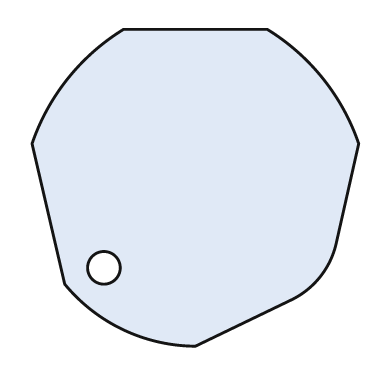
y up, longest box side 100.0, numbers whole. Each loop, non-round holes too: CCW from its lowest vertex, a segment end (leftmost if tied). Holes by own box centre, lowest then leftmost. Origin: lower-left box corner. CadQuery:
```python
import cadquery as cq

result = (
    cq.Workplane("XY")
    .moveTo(50.0, 0.0)
    .lineTo(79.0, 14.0)
    .threePointArc((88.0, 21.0), (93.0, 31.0))
    .lineTo(100.0, 62.0)
    .threePointArc((89.0, 82.0), (72.0, 97.0))
    .lineTo(28.0, 97.0)
    .threePointArc((11.0, 82.0), (0.0, 62.0))
    .lineTo(10.0, 19.0)
    .threePointArc((28.0, 5.0), (50.0, 0.0))
    .close()
    .moveTo(22.0, 24.0)
    .circle(5.0)
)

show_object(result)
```